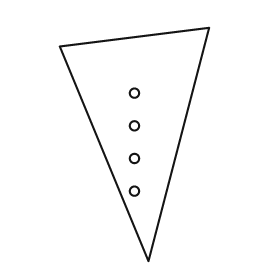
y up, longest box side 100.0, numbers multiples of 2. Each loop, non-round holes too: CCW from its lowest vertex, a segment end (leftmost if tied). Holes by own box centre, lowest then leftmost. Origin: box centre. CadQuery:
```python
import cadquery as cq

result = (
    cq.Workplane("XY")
    .moveTo(6.0, -50.0)
    .lineTo(32.0, 50.0)
    .lineTo(-32.0, 42.0)
    .close()
    .moveTo(0.0, -20.0)
    .circle(2.0)
    .moveTo(0.0, -6.0)
    .circle(2.0)
    .moveTo(0.0, 8.0)
    .circle(2.0)
    .moveTo(0.0, 22.0)
    .circle(2.0)
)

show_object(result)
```